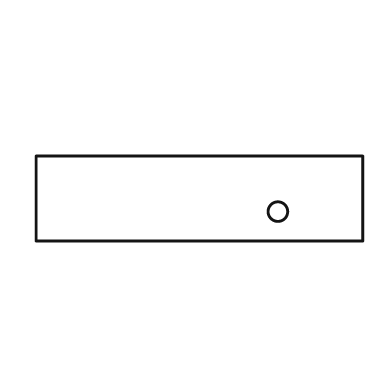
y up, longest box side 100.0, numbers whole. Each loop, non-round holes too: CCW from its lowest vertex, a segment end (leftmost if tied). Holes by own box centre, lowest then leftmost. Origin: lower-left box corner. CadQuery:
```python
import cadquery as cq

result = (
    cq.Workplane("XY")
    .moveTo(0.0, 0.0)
    .lineTo(100.0, 0.0)
    .lineTo(100.0, 26.0)
    .lineTo(0.0, 26.0)
    .close()
    .moveTo(74.0, 9.0)
    .circle(3.0)
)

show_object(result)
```